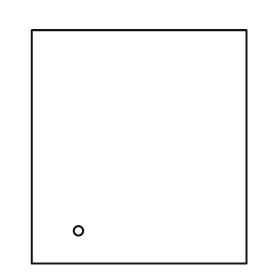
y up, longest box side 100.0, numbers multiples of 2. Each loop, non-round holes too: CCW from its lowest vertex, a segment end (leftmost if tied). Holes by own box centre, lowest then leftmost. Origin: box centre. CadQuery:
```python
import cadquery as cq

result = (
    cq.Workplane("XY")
    .moveTo(-46.0, -50.0)
    .lineTo(46.0, -50.0)
    .lineTo(46.0, 50.0)
    .lineTo(-46.0, 50.0)
    .close()
    .moveTo(-26.0, -36.0)
    .circle(2.0)
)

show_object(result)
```